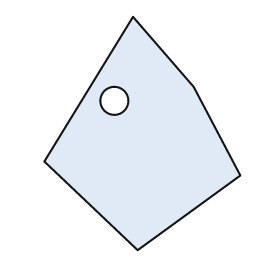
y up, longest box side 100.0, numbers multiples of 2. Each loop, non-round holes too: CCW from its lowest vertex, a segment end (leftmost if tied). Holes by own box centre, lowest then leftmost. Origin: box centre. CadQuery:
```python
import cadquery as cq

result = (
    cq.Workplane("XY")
    .moveTo(-2.0, -50.0)
    .lineTo(42.0, -18.0)
    .lineTo(22.0, 20.0)
    .lineTo(-4.0, 50.0)
    .lineTo(-42.0, -12.0)
    .close()
    .moveTo(-12.0, 14.0)
    .circle(6.0)
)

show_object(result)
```